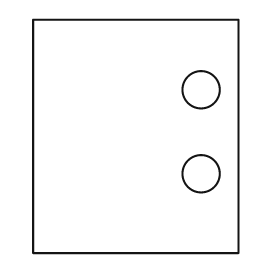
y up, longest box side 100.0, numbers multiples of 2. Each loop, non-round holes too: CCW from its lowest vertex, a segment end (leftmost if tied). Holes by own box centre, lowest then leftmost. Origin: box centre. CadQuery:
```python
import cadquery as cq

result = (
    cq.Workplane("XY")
    .moveTo(-44.0, -50.0)
    .lineTo(44.0, -50.0)
    .lineTo(44.0, 50.0)
    .lineTo(-44.0, 50.0)
    .close()
    .moveTo(28.0, -16.0)
    .circle(8.0)
    .moveTo(28.0, 20.0)
    .circle(8.0)
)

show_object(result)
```